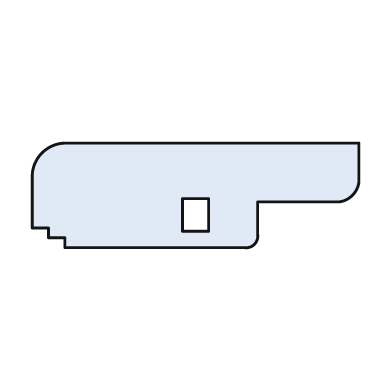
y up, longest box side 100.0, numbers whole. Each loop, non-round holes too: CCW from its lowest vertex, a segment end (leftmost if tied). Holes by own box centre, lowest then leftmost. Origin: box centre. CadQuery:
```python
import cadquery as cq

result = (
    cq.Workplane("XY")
    .moveTo(-40.0, -16.0)
    .lineTo(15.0, -16.0)
    .threePointArc((18.0, -15.0), (19.0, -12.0))
    .lineTo(19.0, -2.0)
    .lineTo(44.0, -2.0)
    .threePointArc((48.0, 0.0), (50.0, 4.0))
    .lineTo(50.0, 16.0)
    .lineTo(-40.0, 16.0)
    .threePointArc((-47.0, 13.0), (-50.0, 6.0))
    .lineTo(-50.0, -10.0)
    .lineTo(-45.0, -10.0)
    .lineTo(-45.0, -13.0)
    .lineTo(-40.0, -13.0)
    .close()
    .moveTo(-4.0, -11.0)
    .lineTo(4.0, -11.0)
    .lineTo(4.0, -1.0)
    .lineTo(-4.0, -1.0)
    .close()
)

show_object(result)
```